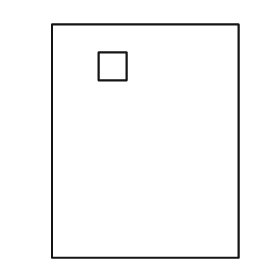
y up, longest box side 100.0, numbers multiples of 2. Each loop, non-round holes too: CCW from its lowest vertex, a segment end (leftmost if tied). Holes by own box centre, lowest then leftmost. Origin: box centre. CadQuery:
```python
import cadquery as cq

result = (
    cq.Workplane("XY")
    .moveTo(-40.0, -50.0)
    .lineTo(40.0, -50.0)
    .lineTo(40.0, 50.0)
    .lineTo(-40.0, 50.0)
    .close()
    .moveTo(-20.0, 26.0)
    .lineTo(-8.0, 26.0)
    .lineTo(-8.0, 38.0)
    .lineTo(-20.0, 38.0)
    .close()
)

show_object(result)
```